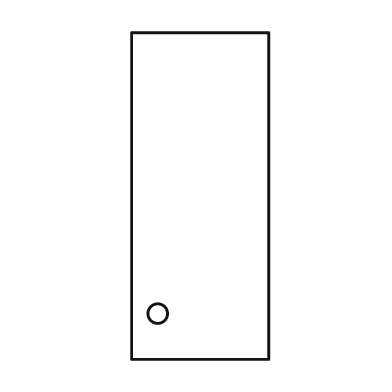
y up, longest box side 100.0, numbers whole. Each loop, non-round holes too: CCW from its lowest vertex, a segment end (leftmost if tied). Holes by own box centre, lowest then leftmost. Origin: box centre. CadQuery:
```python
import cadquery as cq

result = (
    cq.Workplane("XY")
    .moveTo(-21.0, -50.0)
    .lineTo(21.0, -50.0)
    .lineTo(21.0, 50.0)
    .lineTo(-21.0, 50.0)
    .close()
    .moveTo(-13.0, -36.0)
    .circle(3.0)
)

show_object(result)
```